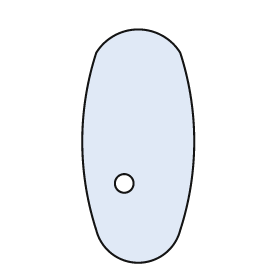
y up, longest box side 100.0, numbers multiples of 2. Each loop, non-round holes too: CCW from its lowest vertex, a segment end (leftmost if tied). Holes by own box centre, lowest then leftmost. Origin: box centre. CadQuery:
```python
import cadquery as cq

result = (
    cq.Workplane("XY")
    .moveTo(-18.0, -36.0)
    .threePointArc((0.0, -50.0), (18.0, -36.0))
    .threePointArc((24.0, 2.0), (18.0, 40.0))
    .threePointArc((0.0, 50.0), (-18.0, 40.0))
    .threePointArc((-24.0, 2.0), (-18.0, -36.0))
    .close()
    .moveTo(-6.0, -16.0)
    .circle(4.0)
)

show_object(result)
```